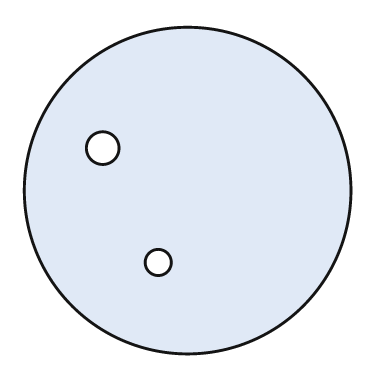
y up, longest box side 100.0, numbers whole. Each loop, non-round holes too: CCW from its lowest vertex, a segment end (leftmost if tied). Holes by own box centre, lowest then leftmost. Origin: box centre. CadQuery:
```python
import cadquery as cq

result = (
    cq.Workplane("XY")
    .moveTo(0.0, 0.0)
    .circle(50.0)
    .moveTo(-9.0, -22.0)
    .circle(4.0)
    .moveTo(-26.0, 13.0)
    .circle(5.0)
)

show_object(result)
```